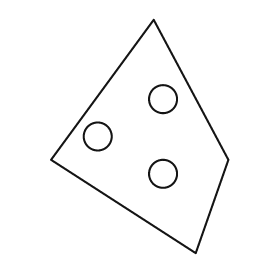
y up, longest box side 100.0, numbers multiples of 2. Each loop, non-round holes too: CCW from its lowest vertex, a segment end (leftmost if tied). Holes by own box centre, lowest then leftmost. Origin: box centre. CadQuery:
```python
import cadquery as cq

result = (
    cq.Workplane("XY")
    .moveTo(24.0, -50.0)
    .lineTo(38.0, -10.0)
    .lineTo(6.0, 50.0)
    .lineTo(-38.0, -10.0)
    .close()
    .moveTo(10.0, -16.0)
    .circle(6.0)
    .moveTo(-18.0, 0.0)
    .circle(6.0)
    .moveTo(10.0, 16.0)
    .circle(6.0)
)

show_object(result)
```